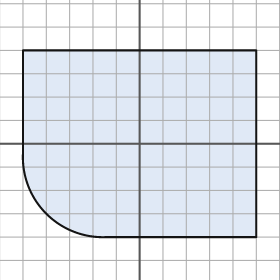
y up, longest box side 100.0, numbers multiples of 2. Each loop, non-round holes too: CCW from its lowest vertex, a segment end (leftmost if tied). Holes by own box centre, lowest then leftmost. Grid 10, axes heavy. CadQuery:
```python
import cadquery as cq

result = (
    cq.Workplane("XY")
    .moveTo(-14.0, -40.0)
    .lineTo(50.0, -40.0)
    .lineTo(50.0, 40.0)
    .lineTo(-50.0, 40.0)
    .lineTo(-50.0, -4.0)
    .threePointArc((-40.0, -30.0), (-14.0, -40.0))
    .close()
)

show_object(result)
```